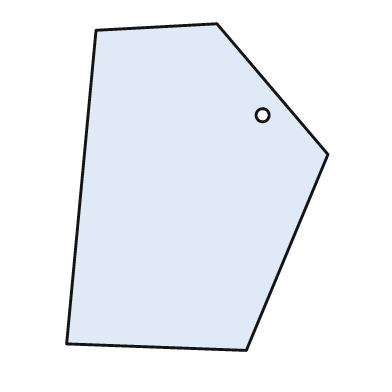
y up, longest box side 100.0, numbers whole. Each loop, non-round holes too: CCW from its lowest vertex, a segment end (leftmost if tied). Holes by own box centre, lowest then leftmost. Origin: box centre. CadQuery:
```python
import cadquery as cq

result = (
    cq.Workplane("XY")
    .moveTo(15.0, -50.0)
    .lineTo(40.0, 10.0)
    .lineTo(6.0, 50.0)
    .lineTo(-31.0, 48.0)
    .lineTo(-40.0, -48.0)
    .close()
    .moveTo(20.0, 22.0)
    .circle(2.0)
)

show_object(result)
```